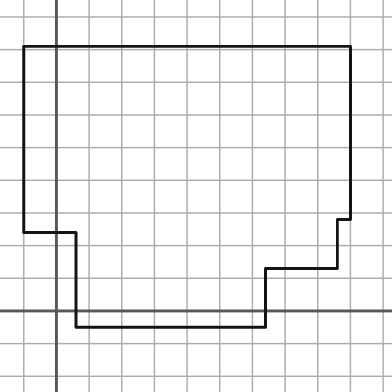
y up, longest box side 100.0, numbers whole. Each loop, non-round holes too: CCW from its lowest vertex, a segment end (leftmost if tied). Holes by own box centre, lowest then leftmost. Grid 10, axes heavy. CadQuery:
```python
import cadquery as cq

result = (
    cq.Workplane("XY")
    .moveTo(6.0, -5.0)
    .lineTo(64.0, -5.0)
    .lineTo(64.0, 13.0)
    .lineTo(86.0, 13.0)
    .lineTo(86.0, 28.0)
    .lineTo(90.0, 28.0)
    .lineTo(90.0, 81.0)
    .lineTo(-10.0, 81.0)
    .lineTo(-10.0, 24.0)
    .lineTo(6.0, 24.0)
    .close()
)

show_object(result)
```